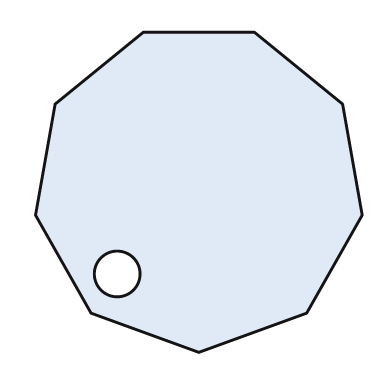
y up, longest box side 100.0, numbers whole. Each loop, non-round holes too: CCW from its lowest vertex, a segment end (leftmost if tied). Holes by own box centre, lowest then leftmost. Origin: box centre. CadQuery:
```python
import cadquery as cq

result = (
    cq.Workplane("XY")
    .moveTo(0.0, -49.0)
    .lineTo(33.0, -37.0)
    .lineTo(50.0, -7.0)
    .lineTo(44.0, 27.0)
    .lineTo(17.0, 49.0)
    .lineTo(-17.0, 49.0)
    .lineTo(-44.0, 27.0)
    .lineTo(-50.0, -7.0)
    .lineTo(-33.0, -37.0)
    .close()
    .moveTo(-25.0, -25.0)
    .circle(7.0)
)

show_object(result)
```